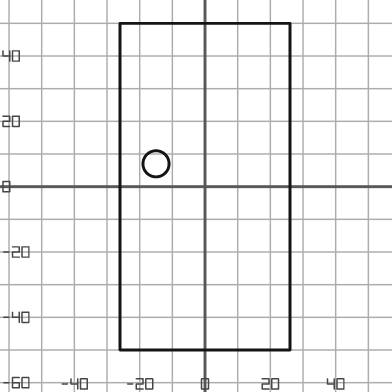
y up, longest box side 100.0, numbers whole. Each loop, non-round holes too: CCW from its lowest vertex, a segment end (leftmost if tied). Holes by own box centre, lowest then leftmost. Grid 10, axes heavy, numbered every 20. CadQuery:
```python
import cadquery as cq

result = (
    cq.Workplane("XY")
    .moveTo(-26.0, -50.0)
    .lineTo(26.0, -50.0)
    .lineTo(26.0, 50.0)
    .lineTo(-26.0, 50.0)
    .close()
    .moveTo(-15.0, 7.0)
    .circle(4.0)
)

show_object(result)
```